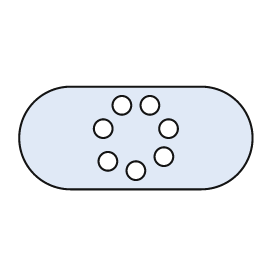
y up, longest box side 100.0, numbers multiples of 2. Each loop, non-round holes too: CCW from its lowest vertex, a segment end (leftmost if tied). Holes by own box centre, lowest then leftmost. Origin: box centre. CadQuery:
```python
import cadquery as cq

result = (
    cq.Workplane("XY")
    .moveTo(-28.0, -22.0)
    .lineTo(28.0, -22.0)
    .threePointArc((50.0, 0.0), (28.0, 22.0))
    .lineTo(-28.0, 22.0)
    .threePointArc((-50.0, 0.0), (-28.0, -22.0))
    .close()
    .moveTo(0.0, -14.0)
    .circle(4.0)
    .moveTo(-12.0, -10.0)
    .circle(4.0)
    .moveTo(12.0, -8.0)
    .circle(4.0)
    .moveTo(-14.0, 4.0)
    .circle(4.0)
    .moveTo(14.0, 4.0)
    .circle(4.0)
    .moveTo(-6.0, 14.0)
    .circle(4.0)
    .moveTo(6.0, 14.0)
    .circle(4.0)
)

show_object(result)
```